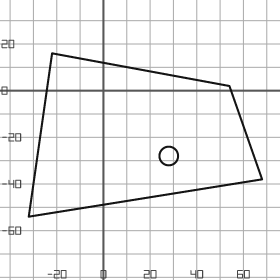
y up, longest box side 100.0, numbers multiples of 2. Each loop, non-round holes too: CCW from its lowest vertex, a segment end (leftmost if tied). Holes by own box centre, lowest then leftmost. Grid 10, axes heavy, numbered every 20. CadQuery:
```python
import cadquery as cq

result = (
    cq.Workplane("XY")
    .moveTo(-32.0, -54.0)
    .lineTo(68.0, -38.0)
    .lineTo(54.0, 2.0)
    .lineTo(-22.0, 16.0)
    .close()
    .moveTo(28.0, -28.0)
    .circle(4.0)
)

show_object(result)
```